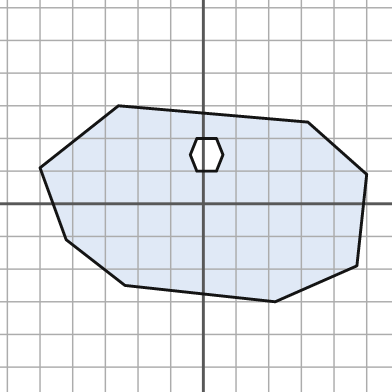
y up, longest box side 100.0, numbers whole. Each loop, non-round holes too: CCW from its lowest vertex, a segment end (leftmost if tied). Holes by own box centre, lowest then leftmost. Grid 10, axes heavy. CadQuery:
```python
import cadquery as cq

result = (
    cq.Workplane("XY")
    .moveTo(22.0, -30.0)
    .lineTo(47.0, -19.0)
    .lineTo(50.0, 9.0)
    .lineTo(32.0, 25.0)
    .lineTo(-26.0, 30.0)
    .lineTo(-50.0, 11.0)
    .lineTo(-42.0, -11.0)
    .lineTo(-24.0, -25.0)
    .close()
    .moveTo(-2.0, 10.0)
    .lineTo(4.0, 10.0)
    .lineTo(6.0, 15.0)
    .lineTo(4.0, 20.0)
    .lineTo(-2.0, 20.0)
    .lineTo(-4.0, 15.0)
    .close()
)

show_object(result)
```